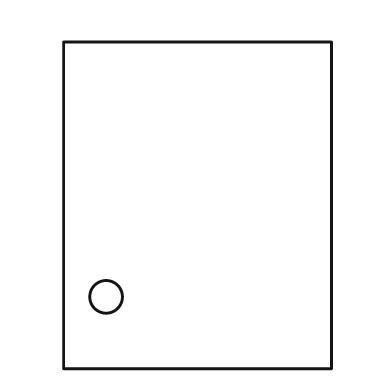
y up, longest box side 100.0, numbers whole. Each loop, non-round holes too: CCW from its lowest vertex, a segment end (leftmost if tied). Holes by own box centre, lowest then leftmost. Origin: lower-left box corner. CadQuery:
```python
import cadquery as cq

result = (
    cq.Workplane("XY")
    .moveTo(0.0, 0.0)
    .lineTo(82.0, 0.0)
    .lineTo(82.0, 100.0)
    .lineTo(0.0, 100.0)
    .close()
    .moveTo(13.0, 22.0)
    .circle(5.0)
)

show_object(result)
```